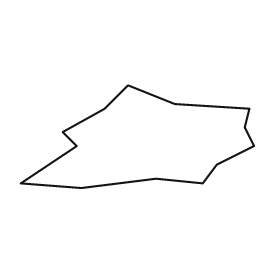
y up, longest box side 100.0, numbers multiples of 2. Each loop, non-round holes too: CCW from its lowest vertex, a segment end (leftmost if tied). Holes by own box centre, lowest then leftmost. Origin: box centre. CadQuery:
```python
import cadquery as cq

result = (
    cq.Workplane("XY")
    .moveTo(-24.0, -22.0)
    .lineTo(8.0, -18.0)
    .lineTo(28.0, -20.0)
    .lineTo(34.0, -12.0)
    .lineTo(50.0, -4.0)
    .lineTo(46.0, 4.0)
    .lineTo(48.0, 12.0)
    .lineTo(16.0, 14.0)
    .lineTo(-4.0, 22.0)
    .lineTo(-14.0, 12.0)
    .lineTo(-32.0, 2.0)
    .lineTo(-26.0, -4.0)
    .lineTo(-50.0, -20.0)
    .close()
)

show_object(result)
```